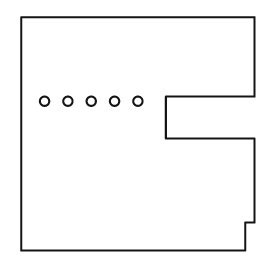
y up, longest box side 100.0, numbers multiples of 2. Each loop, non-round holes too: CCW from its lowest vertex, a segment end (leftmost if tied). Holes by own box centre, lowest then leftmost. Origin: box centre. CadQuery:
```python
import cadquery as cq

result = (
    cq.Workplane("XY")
    .moveTo(-50.0, -50.0)
    .lineTo(46.0, -50.0)
    .lineTo(46.0, -38.0)
    .lineTo(50.0, -38.0)
    .lineTo(50.0, -2.0)
    .lineTo(12.0, -2.0)
    .lineTo(12.0, 16.0)
    .lineTo(50.0, 16.0)
    .lineTo(50.0, 50.0)
    .lineTo(-50.0, 50.0)
    .close()
    .moveTo(-40.0, 14.0)
    .circle(2.0)
    .moveTo(-30.0, 14.0)
    .circle(2.0)
    .moveTo(-20.0, 14.0)
    .circle(2.0)
    .moveTo(-10.0, 14.0)
    .circle(2.0)
    .moveTo(0.0, 14.0)
    .circle(2.0)
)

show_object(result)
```